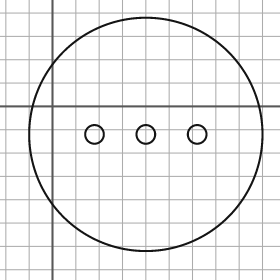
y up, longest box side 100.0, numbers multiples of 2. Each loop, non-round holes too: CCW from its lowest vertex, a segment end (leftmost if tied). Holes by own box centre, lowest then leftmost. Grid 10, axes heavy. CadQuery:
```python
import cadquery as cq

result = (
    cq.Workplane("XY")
    .moveTo(40.0, -12.0)
    .circle(50.0)
    .moveTo(18.0, -12.0)
    .circle(4.0)
    .moveTo(40.0, -12.0)
    .circle(4.0)
    .moveTo(62.0, -12.0)
    .circle(4.0)
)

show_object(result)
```